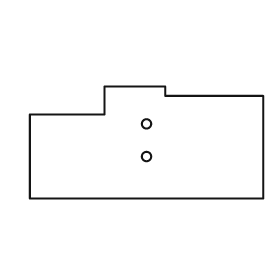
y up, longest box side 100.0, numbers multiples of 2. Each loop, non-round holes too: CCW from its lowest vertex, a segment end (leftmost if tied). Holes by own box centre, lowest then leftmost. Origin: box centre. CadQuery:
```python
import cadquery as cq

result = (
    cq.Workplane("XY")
    .moveTo(-50.0, -24.0)
    .lineTo(50.0, -24.0)
    .lineTo(50.0, 20.0)
    .lineTo(8.0, 20.0)
    .lineTo(8.0, 24.0)
    .lineTo(-18.0, 24.0)
    .lineTo(-18.0, 12.0)
    .lineTo(-50.0, 12.0)
    .close()
    .moveTo(0.0, -6.0)
    .circle(2.0)
    .moveTo(0.0, 8.0)
    .circle(2.0)
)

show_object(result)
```